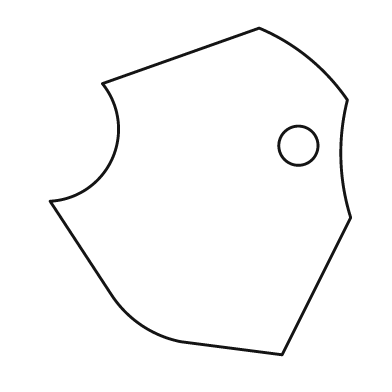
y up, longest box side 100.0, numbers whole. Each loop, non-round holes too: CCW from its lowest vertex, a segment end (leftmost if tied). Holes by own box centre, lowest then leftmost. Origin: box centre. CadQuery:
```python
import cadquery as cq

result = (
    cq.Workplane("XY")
    .moveTo(25.0, -50.0)
    .lineTo(46.0, -8.0)
    .threePointArc((43.0, 10.0), (45.0, 28.0))
    .threePointArc((33.0, 41.0), (18.0, 50.0))
    .lineTo(-30.0, 33.0)
    .threePointArc((-27.0, 10.0), (-46.0, -3.0))
    .lineTo(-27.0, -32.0)
    .threePointArc((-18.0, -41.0), (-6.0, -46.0))
    .close()
    .moveTo(30.0, 14.0)
    .circle(6.0)
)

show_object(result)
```